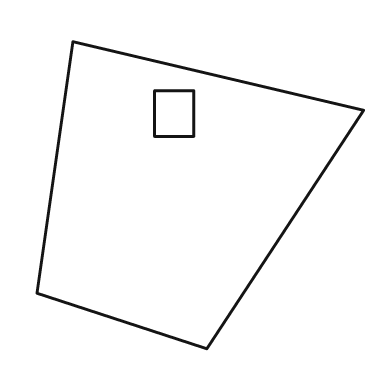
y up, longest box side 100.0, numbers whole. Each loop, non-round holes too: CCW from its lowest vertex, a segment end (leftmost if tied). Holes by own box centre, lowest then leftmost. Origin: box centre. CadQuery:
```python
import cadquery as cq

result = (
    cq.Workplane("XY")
    .moveTo(2.0, -47.0)
    .lineTo(50.0, 26.0)
    .lineTo(-39.0, 47.0)
    .lineTo(-50.0, -30.0)
    .close()
    .moveTo(-14.0, 18.0)
    .lineTo(-2.0, 18.0)
    .lineTo(-2.0, 32.0)
    .lineTo(-14.0, 32.0)
    .close()
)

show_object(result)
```